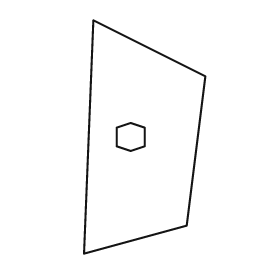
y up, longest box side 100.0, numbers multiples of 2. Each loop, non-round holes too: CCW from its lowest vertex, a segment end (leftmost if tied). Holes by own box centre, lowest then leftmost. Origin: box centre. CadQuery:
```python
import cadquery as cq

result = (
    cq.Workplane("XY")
    .moveTo(-26.0, -50.0)
    .lineTo(18.0, -38.0)
    .lineTo(26.0, 26.0)
    .lineTo(-22.0, 50.0)
    .close()
    .moveTo(-6.0, -6.0)
    .lineTo(0.0, -4.0)
    .lineTo(0.0, 4.0)
    .lineTo(-6.0, 6.0)
    .lineTo(-12.0, 4.0)
    .lineTo(-12.0, -4.0)
    .close()
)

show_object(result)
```